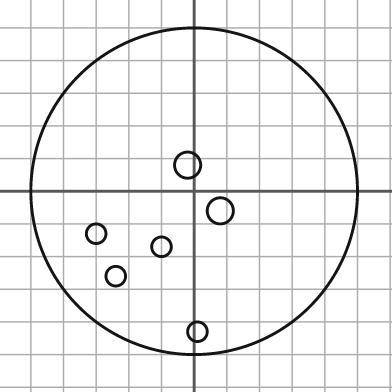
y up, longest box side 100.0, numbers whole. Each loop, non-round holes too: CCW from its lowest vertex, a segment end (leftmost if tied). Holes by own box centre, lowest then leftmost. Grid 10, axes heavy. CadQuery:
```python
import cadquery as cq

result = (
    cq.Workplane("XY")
    .moveTo(0.0, 0.0)
    .circle(50.0)
    .moveTo(1.0, -43.0)
    .circle(3.0)
    .moveTo(-24.0, -26.0)
    .circle(3.0)
    .moveTo(-10.0, -17.0)
    .circle(3.0)
    .moveTo(-30.0, -13.0)
    .circle(3.0)
    .moveTo(8.0, -6.0)
    .circle(4.0)
    .moveTo(-2.0, 8.0)
    .circle(4.0)
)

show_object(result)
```